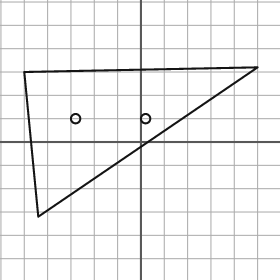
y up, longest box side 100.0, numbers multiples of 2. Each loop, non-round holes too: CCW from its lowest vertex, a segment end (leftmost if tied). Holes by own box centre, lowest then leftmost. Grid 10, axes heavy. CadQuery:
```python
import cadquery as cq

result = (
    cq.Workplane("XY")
    .moveTo(-44.0, -32.0)
    .lineTo(50.0, 32.0)
    .lineTo(-50.0, 30.0)
    .close()
    .moveTo(-28.0, 10.0)
    .circle(2.0)
    .moveTo(2.0, 10.0)
    .circle(2.0)
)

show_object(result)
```